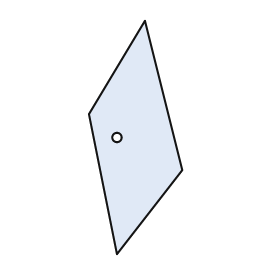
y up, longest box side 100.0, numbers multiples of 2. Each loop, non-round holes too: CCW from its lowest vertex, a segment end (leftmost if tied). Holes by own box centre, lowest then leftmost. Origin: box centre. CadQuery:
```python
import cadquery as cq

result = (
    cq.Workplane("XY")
    .moveTo(-8.0, -50.0)
    .lineTo(20.0, -14.0)
    .lineTo(4.0, 50.0)
    .lineTo(-20.0, 10.0)
    .close()
    .moveTo(-8.0, 0.0)
    .circle(2.0)
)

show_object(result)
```